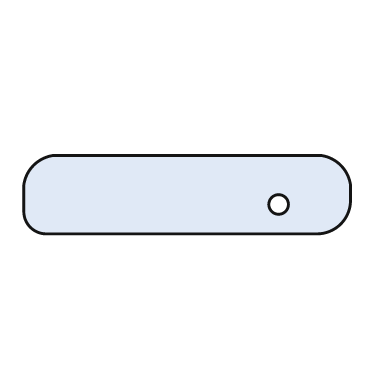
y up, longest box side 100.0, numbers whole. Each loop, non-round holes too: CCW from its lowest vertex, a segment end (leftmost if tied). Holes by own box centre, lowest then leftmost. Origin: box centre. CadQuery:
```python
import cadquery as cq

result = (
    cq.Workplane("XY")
    .moveTo(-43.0, -12.0)
    .lineTo(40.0, -12.0)
    .threePointArc((47.0, -9.0), (50.0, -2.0))
    .lineTo(50.0, 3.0)
    .threePointArc((47.0, 9.0), (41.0, 12.0))
    .lineTo(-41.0, 12.0)
    .threePointArc((-47.0, 9.0), (-50.0, 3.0))
    .lineTo(-50.0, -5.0)
    .threePointArc((-48.0, -10.0), (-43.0, -12.0))
    .close()
    .moveTo(28.0, -3.0)
    .circle(3.0)
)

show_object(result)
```